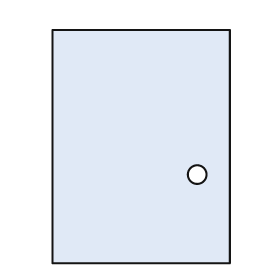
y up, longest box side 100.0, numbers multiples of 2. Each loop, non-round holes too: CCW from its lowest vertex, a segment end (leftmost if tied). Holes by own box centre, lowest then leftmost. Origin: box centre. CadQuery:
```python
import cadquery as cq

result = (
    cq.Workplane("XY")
    .moveTo(-38.0, -50.0)
    .lineTo(38.0, -50.0)
    .lineTo(38.0, 50.0)
    .lineTo(-38.0, 50.0)
    .close()
    .moveTo(24.0, -12.0)
    .circle(4.0)
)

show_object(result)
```